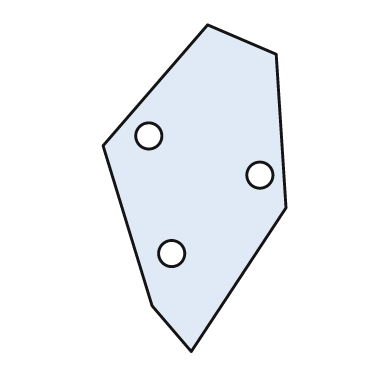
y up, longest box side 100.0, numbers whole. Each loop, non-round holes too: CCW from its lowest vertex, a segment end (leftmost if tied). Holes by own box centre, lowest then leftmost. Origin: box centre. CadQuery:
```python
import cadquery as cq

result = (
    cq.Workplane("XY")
    .moveTo(-1.0, -50.0)
    .lineTo(28.0, -6.0)
    .lineTo(25.0, 41.0)
    .lineTo(4.0, 50.0)
    .lineTo(-28.0, 13.0)
    .lineTo(-13.0, -36.0)
    .close()
    .moveTo(-7.0, -20.0)
    .circle(4.0)
    .moveTo(20.0, 4.0)
    .circle(4.0)
    .moveTo(-14.0, 16.0)
    .circle(4.0)
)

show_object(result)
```